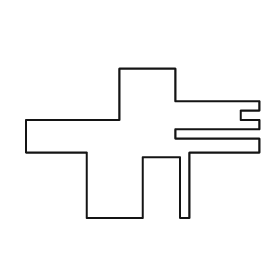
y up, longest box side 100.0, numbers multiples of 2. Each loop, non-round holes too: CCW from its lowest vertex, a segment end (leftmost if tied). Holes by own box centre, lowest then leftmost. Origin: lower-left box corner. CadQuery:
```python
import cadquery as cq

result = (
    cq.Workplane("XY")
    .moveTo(26.0, 0.0)
    .lineTo(50.0, 0.0)
    .lineTo(50.0, 26.0)
    .lineTo(66.0, 26.0)
    .lineTo(66.0, 0.0)
    .lineTo(70.0, 0.0)
    .lineTo(70.0, 28.0)
    .lineTo(100.0, 28.0)
    .lineTo(100.0, 34.0)
    .lineTo(64.0, 34.0)
    .lineTo(64.0, 38.0)
    .lineTo(100.0, 38.0)
    .lineTo(100.0, 42.0)
    .lineTo(92.0, 42.0)
    .lineTo(92.0, 46.0)
    .lineTo(100.0, 46.0)
    .lineTo(100.0, 50.0)
    .lineTo(64.0, 50.0)
    .lineTo(64.0, 64.0)
    .lineTo(40.0, 64.0)
    .lineTo(40.0, 42.0)
    .lineTo(0.0, 42.0)
    .lineTo(0.0, 28.0)
    .lineTo(26.0, 28.0)
    .close()
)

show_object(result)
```